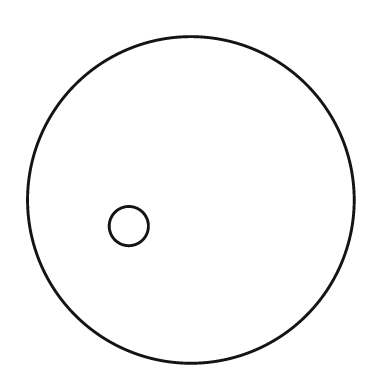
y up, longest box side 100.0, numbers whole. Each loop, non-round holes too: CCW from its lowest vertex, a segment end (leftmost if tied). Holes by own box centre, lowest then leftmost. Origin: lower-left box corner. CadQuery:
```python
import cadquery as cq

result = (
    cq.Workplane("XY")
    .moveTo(50.0, 50.0)
    .circle(50.0)
    .moveTo(31.0, 42.0)
    .circle(6.0)
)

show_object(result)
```